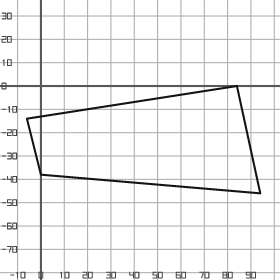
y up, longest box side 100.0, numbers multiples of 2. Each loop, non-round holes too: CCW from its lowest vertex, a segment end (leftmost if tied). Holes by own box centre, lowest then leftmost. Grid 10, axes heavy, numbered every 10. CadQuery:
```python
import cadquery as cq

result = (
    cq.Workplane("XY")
    .moveTo(94.0, -46.0)
    .lineTo(84.0, 0.0)
    .lineTo(-6.0, -14.0)
    .lineTo(0.0, -38.0)
    .close()
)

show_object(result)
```